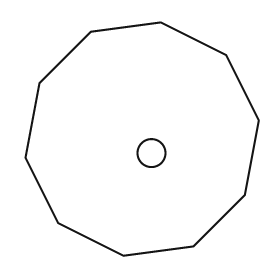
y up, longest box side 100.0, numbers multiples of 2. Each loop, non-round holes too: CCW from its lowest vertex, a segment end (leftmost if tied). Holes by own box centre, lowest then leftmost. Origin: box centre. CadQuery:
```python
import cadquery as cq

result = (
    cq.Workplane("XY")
    .moveTo(-8.0, -50.0)
    .lineTo(22.0, -46.0)
    .lineTo(44.0, -24.0)
    .lineTo(50.0, 8.0)
    .lineTo(36.0, 36.0)
    .lineTo(8.0, 50.0)
    .lineTo(-22.0, 46.0)
    .lineTo(-44.0, 24.0)
    .lineTo(-50.0, -8.0)
    .lineTo(-36.0, -36.0)
    .close()
    .moveTo(4.0, -6.0)
    .circle(6.0)
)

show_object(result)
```